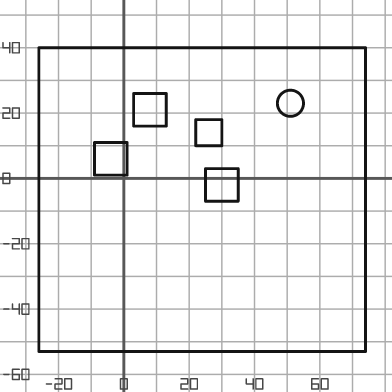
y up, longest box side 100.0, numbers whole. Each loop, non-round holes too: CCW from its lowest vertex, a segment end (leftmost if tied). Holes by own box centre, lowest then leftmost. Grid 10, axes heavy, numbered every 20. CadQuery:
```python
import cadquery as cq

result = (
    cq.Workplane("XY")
    .moveTo(-26.0, -53.0)
    .lineTo(74.0, -53.0)
    .lineTo(74.0, 40.0)
    .lineTo(-26.0, 40.0)
    .close()
    .moveTo(25.0, -7.0)
    .lineTo(35.0, -7.0)
    .lineTo(35.0, 3.0)
    .lineTo(25.0, 3.0)
    .close()
    .moveTo(-9.0, 1.0)
    .lineTo(1.0, 1.0)
    .lineTo(1.0, 11.0)
    .lineTo(-9.0, 11.0)
    .close()
    .moveTo(22.0, 10.0)
    .lineTo(30.0, 10.0)
    .lineTo(30.0, 18.0)
    .lineTo(22.0, 18.0)
    .close()
    .moveTo(3.0, 16.0)
    .lineTo(13.0, 16.0)
    .lineTo(13.0, 26.0)
    .lineTo(3.0, 26.0)
    .close()
    .moveTo(51.0, 23.0)
    .circle(4.0)
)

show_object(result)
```